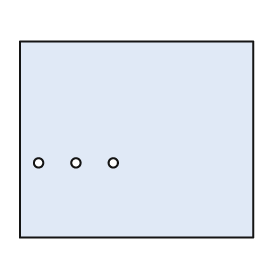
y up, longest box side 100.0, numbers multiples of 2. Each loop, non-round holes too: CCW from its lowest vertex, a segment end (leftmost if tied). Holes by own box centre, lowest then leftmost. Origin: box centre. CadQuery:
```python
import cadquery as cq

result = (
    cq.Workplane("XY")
    .moveTo(-50.0, -42.0)
    .lineTo(50.0, -42.0)
    .lineTo(50.0, 42.0)
    .lineTo(-50.0, 42.0)
    .close()
    .moveTo(-42.0, -10.0)
    .circle(2.0)
    .moveTo(-26.0, -10.0)
    .circle(2.0)
    .moveTo(-10.0, -10.0)
    .circle(2.0)
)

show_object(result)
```